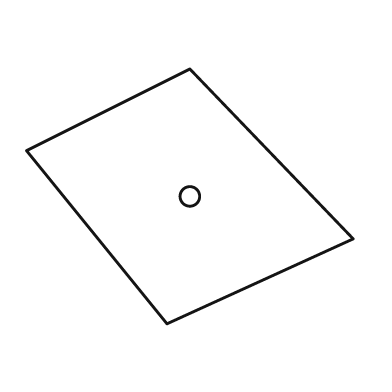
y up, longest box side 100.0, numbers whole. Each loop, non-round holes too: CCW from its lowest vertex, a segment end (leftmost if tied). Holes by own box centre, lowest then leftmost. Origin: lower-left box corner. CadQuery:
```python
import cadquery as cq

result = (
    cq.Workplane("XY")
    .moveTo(43.0, 0.0)
    .lineTo(100.0, 26.0)
    .lineTo(50.0, 78.0)
    .lineTo(0.0, 53.0)
    .close()
    .moveTo(50.0, 39.0)
    .circle(3.0)
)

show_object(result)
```